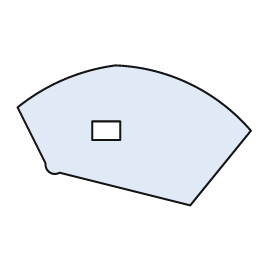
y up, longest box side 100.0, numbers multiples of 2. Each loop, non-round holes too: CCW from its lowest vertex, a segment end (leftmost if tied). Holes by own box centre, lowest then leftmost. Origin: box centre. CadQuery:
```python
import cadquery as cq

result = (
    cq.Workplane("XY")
    .moveTo(24.0, -30.0)
    .lineTo(50.0, 2.0)
    .threePointArc((24.0, 22.0), (-8.0, 30.0))
    .threePointArc((-30.0, 24.0), (-50.0, 12.0))
    .lineTo(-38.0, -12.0)
    .threePointArc((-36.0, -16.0), (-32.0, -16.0))
    .close()
    .moveTo(-18.0, -2.0)
    .lineTo(-6.0, -2.0)
    .lineTo(-6.0, 6.0)
    .lineTo(-18.0, 6.0)
    .close()
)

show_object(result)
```